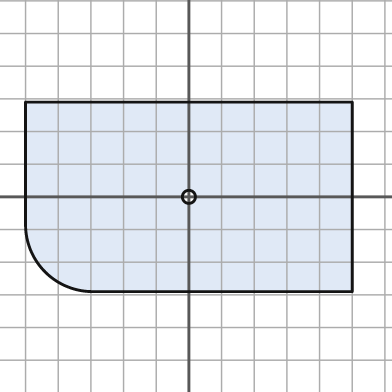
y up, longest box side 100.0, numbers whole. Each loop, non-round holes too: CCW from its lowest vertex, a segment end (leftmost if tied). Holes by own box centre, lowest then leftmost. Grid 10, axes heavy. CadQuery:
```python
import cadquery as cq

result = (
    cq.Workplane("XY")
    .moveTo(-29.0, -29.0)
    .lineTo(50.0, -29.0)
    .lineTo(50.0, 29.0)
    .lineTo(-50.0, 29.0)
    .lineTo(-50.0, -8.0)
    .threePointArc((-44.0, -23.0), (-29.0, -29.0))
    .close()
    .moveTo(0.0, 0.0)
    .circle(2.0)
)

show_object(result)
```